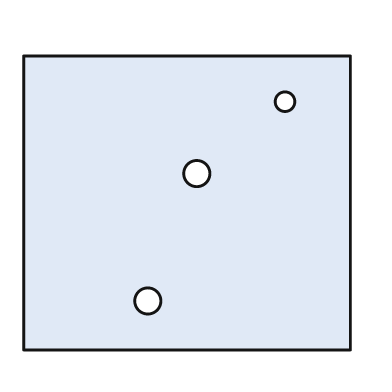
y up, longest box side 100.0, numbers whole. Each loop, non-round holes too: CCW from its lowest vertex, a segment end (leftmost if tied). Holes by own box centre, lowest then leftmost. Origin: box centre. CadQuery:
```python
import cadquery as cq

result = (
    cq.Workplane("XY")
    .moveTo(-50.0, -45.0)
    .lineTo(50.0, -45.0)
    .lineTo(50.0, 45.0)
    .lineTo(-50.0, 45.0)
    .close()
    .moveTo(-12.0, -30.0)
    .circle(4.0)
    .moveTo(3.0, 9.0)
    .circle(4.0)
    .moveTo(30.0, 31.0)
    .circle(3.0)
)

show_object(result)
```